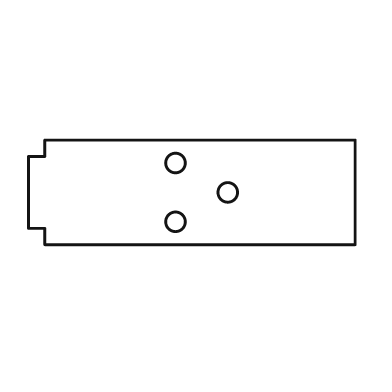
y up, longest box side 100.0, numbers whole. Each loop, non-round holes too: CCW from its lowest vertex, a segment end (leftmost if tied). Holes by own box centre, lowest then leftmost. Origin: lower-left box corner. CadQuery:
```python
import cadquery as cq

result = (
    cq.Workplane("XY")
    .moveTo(5.0, 0.0)
    .lineTo(100.0, 0.0)
    .lineTo(100.0, 32.0)
    .lineTo(5.0, 32.0)
    .lineTo(5.0, 27.0)
    .lineTo(0.0, 27.0)
    .lineTo(0.0, 5.0)
    .lineTo(5.0, 5.0)
    .close()
    .moveTo(45.0, 7.0)
    .circle(3.0)
    .moveTo(61.0, 16.0)
    .circle(3.0)
    .moveTo(45.0, 25.0)
    .circle(3.0)
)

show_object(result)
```